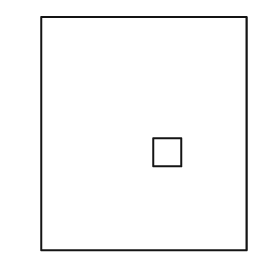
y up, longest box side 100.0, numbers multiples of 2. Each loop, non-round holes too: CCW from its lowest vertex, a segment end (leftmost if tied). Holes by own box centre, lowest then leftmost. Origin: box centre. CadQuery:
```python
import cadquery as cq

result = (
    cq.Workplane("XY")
    .moveTo(-44.0, -50.0)
    .lineTo(44.0, -50.0)
    .lineTo(44.0, 50.0)
    .lineTo(-44.0, 50.0)
    .close()
    .moveTo(4.0, -14.0)
    .lineTo(16.0, -14.0)
    .lineTo(16.0, -2.0)
    .lineTo(4.0, -2.0)
    .close()
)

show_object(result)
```